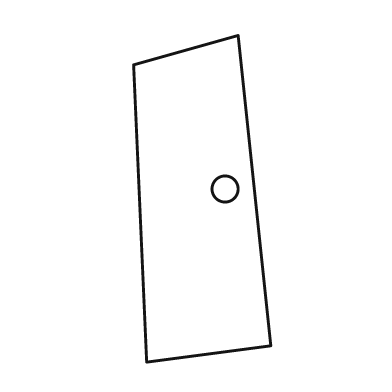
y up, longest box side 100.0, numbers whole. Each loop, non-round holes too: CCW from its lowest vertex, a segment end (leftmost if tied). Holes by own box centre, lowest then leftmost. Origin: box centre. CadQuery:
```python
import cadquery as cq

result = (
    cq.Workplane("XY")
    .moveTo(-17.0, -50.0)
    .lineTo(21.0, -45.0)
    .lineTo(11.0, 50.0)
    .lineTo(-21.0, 41.0)
    .close()
    .moveTo(7.0, 3.0)
    .circle(4.0)
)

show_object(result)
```